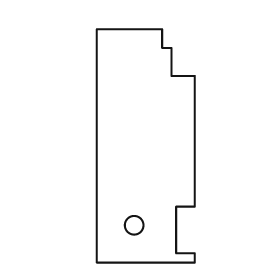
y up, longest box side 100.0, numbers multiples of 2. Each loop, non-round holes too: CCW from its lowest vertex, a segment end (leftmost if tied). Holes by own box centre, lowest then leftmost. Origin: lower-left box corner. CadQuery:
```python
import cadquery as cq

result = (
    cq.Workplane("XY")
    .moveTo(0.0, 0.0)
    .lineTo(42.0, 0.0)
    .lineTo(42.0, 4.0)
    .lineTo(34.0, 4.0)
    .lineTo(34.0, 24.0)
    .lineTo(42.0, 24.0)
    .lineTo(42.0, 80.0)
    .lineTo(32.0, 80.0)
    .lineTo(32.0, 92.0)
    .lineTo(28.0, 92.0)
    .lineTo(28.0, 100.0)
    .lineTo(0.0, 100.0)
    .close()
    .moveTo(16.0, 16.0)
    .circle(4.0)
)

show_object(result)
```